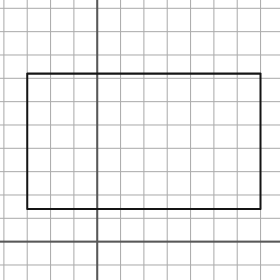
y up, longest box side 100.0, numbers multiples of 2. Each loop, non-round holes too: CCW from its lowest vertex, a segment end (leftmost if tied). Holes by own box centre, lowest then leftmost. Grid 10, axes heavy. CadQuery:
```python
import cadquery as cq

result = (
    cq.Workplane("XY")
    .moveTo(-30.0, 14.0)
    .lineTo(70.0, 14.0)
    .lineTo(70.0, 72.0)
    .lineTo(-30.0, 72.0)
    .close()
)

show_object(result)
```